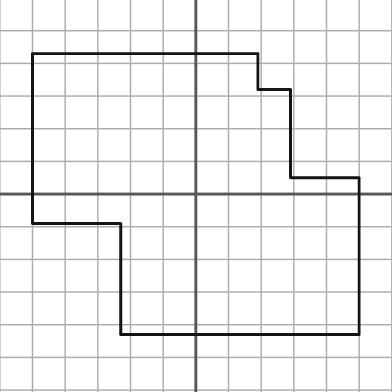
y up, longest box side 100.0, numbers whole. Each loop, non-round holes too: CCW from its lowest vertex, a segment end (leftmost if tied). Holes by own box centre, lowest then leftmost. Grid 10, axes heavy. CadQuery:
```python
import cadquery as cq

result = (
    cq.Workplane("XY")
    .moveTo(-23.0, -43.0)
    .lineTo(50.0, -43.0)
    .lineTo(50.0, 5.0)
    .lineTo(29.0, 5.0)
    .lineTo(29.0, 32.0)
    .lineTo(19.0, 32.0)
    .lineTo(19.0, 43.0)
    .lineTo(-50.0, 43.0)
    .lineTo(-50.0, -9.0)
    .lineTo(-23.0, -9.0)
    .close()
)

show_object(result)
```